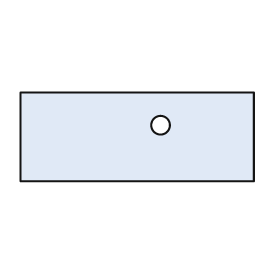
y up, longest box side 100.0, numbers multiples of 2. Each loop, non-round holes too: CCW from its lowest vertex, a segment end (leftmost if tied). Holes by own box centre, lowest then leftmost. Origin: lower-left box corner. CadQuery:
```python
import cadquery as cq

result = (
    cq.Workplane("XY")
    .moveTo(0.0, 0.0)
    .lineTo(100.0, 0.0)
    .lineTo(100.0, 38.0)
    .lineTo(0.0, 38.0)
    .close()
    .moveTo(60.0, 24.0)
    .circle(4.0)
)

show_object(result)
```